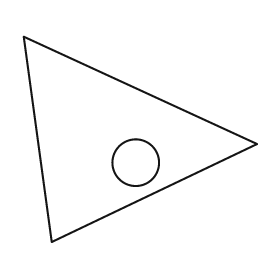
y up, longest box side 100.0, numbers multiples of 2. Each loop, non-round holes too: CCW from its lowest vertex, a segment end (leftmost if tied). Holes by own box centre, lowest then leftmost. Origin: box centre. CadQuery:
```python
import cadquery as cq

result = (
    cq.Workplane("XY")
    .moveTo(-38.0, -44.0)
    .lineTo(50.0, -2.0)
    .lineTo(-50.0, 44.0)
    .close()
    .moveTo(-2.0, -10.0)
    .circle(10.0)
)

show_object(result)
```